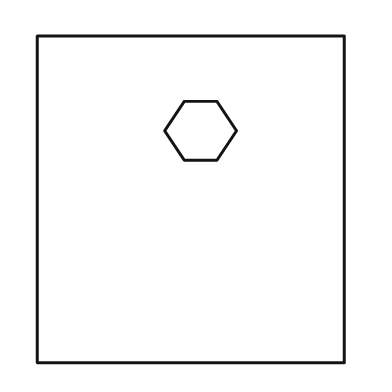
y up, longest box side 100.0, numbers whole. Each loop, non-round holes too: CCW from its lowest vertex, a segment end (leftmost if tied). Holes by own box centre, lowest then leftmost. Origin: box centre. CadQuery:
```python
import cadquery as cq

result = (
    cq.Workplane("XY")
    .moveTo(-47.0, -50.0)
    .lineTo(47.0, -50.0)
    .lineTo(47.0, 50.0)
    .lineTo(-47.0, 50.0)
    .close()
    .moveTo(-2.0, 12.0)
    .lineTo(8.0, 12.0)
    .lineTo(14.0, 21.0)
    .lineTo(8.0, 30.0)
    .lineTo(-2.0, 30.0)
    .lineTo(-8.0, 21.0)
    .close()
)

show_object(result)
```